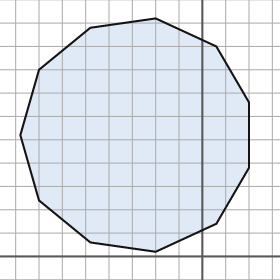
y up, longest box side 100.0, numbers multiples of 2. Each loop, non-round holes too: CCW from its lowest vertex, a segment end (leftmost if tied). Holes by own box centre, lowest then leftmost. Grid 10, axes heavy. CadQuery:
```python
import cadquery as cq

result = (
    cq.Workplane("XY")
    .moveTo(-20.0, 2.0)
    .lineTo(6.0, 14.0)
    .lineTo(20.0, 38.0)
    .lineTo(20.0, 66.0)
    .lineTo(6.0, 90.0)
    .lineTo(-20.0, 102.0)
    .lineTo(-48.0, 98.0)
    .lineTo(-70.0, 80.0)
    .lineTo(-78.0, 52.0)
    .lineTo(-70.0, 24.0)
    .lineTo(-48.0, 6.0)
    .close()
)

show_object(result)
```